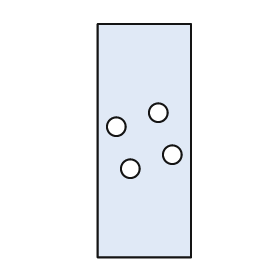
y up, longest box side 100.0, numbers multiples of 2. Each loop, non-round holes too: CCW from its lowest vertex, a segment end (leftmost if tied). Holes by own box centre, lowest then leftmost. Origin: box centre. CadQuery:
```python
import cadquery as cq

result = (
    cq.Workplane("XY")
    .moveTo(-20.0, -50.0)
    .lineTo(20.0, -50.0)
    .lineTo(20.0, 50.0)
    .lineTo(-20.0, 50.0)
    .close()
    .moveTo(-6.0, -12.0)
    .circle(4.0)
    .moveTo(12.0, -6.0)
    .circle(4.0)
    .moveTo(-12.0, 6.0)
    .circle(4.0)
    .moveTo(6.0, 12.0)
    .circle(4.0)
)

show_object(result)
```